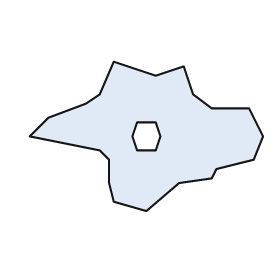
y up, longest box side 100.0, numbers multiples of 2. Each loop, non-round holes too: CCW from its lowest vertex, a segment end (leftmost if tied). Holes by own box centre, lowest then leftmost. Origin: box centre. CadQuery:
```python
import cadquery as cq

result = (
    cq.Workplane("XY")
    .moveTo(0.0, -32.0)
    .lineTo(14.0, -20.0)
    .lineTo(28.0, -18.0)
    .lineTo(30.0, -14.0)
    .lineTo(46.0, -10.0)
    .lineTo(50.0, 0.0)
    .lineTo(44.0, 12.0)
    .lineTo(28.0, 12.0)
    .lineTo(20.0, 18.0)
    .lineTo(16.0, 30.0)
    .lineTo(4.0, 26.0)
    .lineTo(-14.0, 32.0)
    .lineTo(-20.0, 18.0)
    .lineTo(-26.0, 14.0)
    .lineTo(-42.0, 8.0)
    .lineTo(-50.0, 0.0)
    .lineTo(-20.0, -6.0)
    .lineTo(-16.0, -10.0)
    .lineTo(-16.0, -20.0)
    .lineTo(-14.0, -28.0)
    .close()
    .moveTo(-4.0, -6.0)
    .lineTo(4.0, -6.0)
    .lineTo(6.0, 0.0)
    .lineTo(4.0, 6.0)
    .lineTo(-4.0, 6.0)
    .lineTo(-6.0, 0.0)
    .close()
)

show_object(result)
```